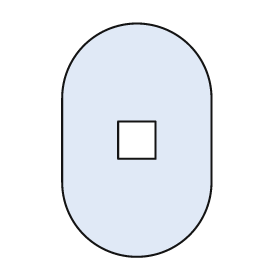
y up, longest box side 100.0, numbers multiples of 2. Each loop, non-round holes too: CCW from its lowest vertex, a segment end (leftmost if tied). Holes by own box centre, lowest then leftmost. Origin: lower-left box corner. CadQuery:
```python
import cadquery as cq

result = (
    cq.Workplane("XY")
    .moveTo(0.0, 32.0)
    .threePointArc((32.0, 0.0), (64.0, 32.0))
    .lineTo(64.0, 68.0)
    .threePointArc((32.0, 100.0), (0.0, 68.0))
    .close()
    .moveTo(24.0, 42.0)
    .lineTo(40.0, 42.0)
    .lineTo(40.0, 58.0)
    .lineTo(24.0, 58.0)
    .close()
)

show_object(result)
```